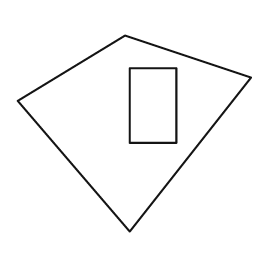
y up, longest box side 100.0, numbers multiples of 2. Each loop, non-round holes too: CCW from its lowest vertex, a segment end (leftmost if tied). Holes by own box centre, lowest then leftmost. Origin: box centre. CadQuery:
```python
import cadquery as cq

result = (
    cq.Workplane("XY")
    .moveTo(-2.0, -42.0)
    .lineTo(50.0, 24.0)
    .lineTo(-4.0, 42.0)
    .lineTo(-50.0, 14.0)
    .close()
    .moveTo(-2.0, -4.0)
    .lineTo(18.0, -4.0)
    .lineTo(18.0, 28.0)
    .lineTo(-2.0, 28.0)
    .close()
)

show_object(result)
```